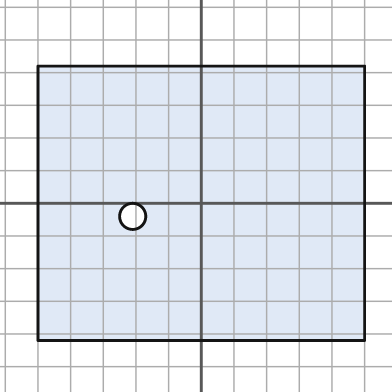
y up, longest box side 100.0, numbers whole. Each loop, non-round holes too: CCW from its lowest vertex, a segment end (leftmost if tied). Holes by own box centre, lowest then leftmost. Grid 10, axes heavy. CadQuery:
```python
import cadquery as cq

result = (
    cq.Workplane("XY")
    .moveTo(-50.0, -42.0)
    .lineTo(50.0, -42.0)
    .lineTo(50.0, 42.0)
    .lineTo(-50.0, 42.0)
    .close()
    .moveTo(-21.0, -4.0)
    .circle(4.0)
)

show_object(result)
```